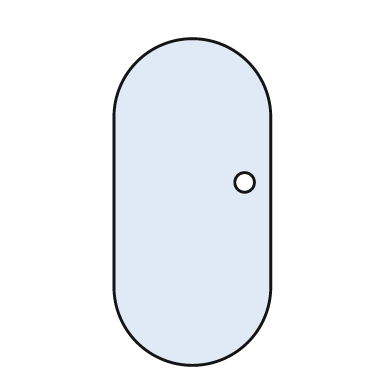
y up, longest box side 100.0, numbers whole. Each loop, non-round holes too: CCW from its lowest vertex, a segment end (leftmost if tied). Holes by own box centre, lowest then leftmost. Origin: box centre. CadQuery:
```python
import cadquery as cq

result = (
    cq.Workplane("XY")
    .moveTo(-24.0, -26.0)
    .threePointArc((0.0, -50.0), (24.0, -26.0))
    .lineTo(24.0, 26.0)
    .threePointArc((0.0, 50.0), (-24.0, 26.0))
    .close()
    .moveTo(16.0, 6.0)
    .circle(3.0)
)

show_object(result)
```